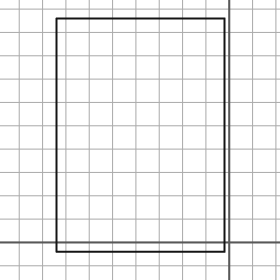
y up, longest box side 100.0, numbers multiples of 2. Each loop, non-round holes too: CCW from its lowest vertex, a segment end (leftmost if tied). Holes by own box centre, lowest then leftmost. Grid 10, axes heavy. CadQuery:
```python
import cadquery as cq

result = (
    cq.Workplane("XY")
    .moveTo(-74.0, -4.0)
    .lineTo(-2.0, -4.0)
    .lineTo(-2.0, 96.0)
    .lineTo(-74.0, 96.0)
    .close()
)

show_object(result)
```